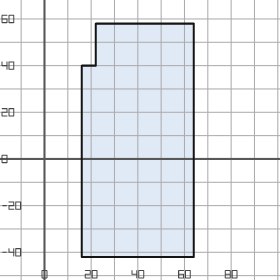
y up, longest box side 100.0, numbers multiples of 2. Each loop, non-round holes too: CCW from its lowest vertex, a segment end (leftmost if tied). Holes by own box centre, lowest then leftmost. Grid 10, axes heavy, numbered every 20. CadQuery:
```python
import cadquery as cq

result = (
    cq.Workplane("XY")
    .moveTo(16.0, -42.0)
    .lineTo(64.0, -42.0)
    .lineTo(64.0, 58.0)
    .lineTo(22.0, 58.0)
    .lineTo(22.0, 40.0)
    .lineTo(16.0, 40.0)
    .close()
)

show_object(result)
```